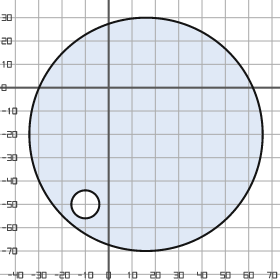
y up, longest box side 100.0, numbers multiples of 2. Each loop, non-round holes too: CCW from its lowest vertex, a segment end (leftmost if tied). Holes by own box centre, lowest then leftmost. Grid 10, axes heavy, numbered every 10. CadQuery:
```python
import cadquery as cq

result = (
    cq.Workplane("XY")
    .moveTo(16.0, -20.0)
    .circle(50.0)
    .moveTo(-10.0, -50.0)
    .circle(6.0)
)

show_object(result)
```